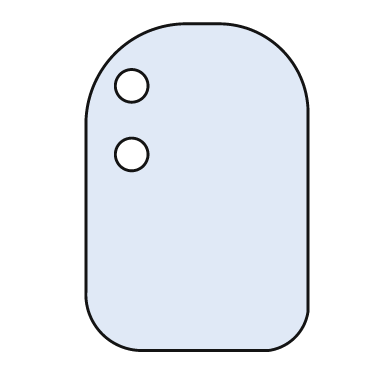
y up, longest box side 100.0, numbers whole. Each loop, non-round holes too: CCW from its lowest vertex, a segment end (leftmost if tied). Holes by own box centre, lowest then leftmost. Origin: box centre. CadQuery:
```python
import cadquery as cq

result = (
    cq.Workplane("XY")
    .moveTo(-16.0, -50.0)
    .lineTo(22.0, -50.0)
    .threePointArc((30.0, -46.0), (34.0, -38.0))
    .lineTo(34.0, 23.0)
    .threePointArc((26.0, 42.0), (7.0, 50.0))
    .lineTo(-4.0, 50.0)
    .threePointArc((-25.0, 41.0), (-34.0, 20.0))
    .lineTo(-34.0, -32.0)
    .threePointArc((-29.0, -45.0), (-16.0, -50.0))
    .close()
    .moveTo(-20.0, 10.0)
    .circle(5.0)
    .moveTo(-20.0, 31.0)
    .circle(5.0)
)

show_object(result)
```